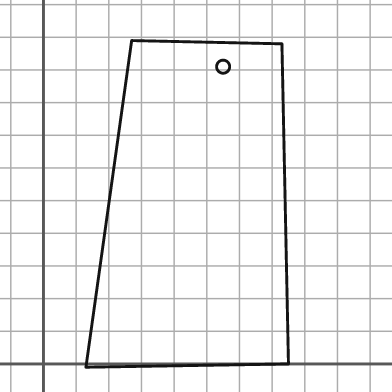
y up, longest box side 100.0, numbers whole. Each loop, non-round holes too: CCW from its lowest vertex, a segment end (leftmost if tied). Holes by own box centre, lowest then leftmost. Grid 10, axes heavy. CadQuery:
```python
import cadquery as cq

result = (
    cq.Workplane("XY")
    .moveTo(13.0, -1.0)
    .lineTo(75.0, 0.0)
    .lineTo(73.0, 98.0)
    .lineTo(27.0, 99.0)
    .close()
    .moveTo(55.0, 91.0)
    .circle(2.0)
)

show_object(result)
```